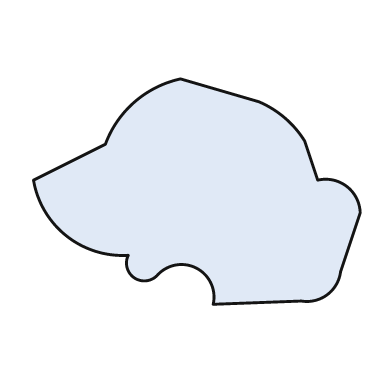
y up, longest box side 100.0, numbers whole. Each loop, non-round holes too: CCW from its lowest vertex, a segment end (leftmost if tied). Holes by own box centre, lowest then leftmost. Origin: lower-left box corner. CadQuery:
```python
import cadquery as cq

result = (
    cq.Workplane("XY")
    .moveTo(55.0, 0.0)
    .lineTo(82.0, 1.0)
    .threePointArc((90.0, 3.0), (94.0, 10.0))
    .lineTo(100.0, 28.0)
    .threePointArc((96.0, 36.0), (87.0, 38.0))
    .lineTo(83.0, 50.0)
    .threePointArc((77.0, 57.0), (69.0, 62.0))
    .lineTo(45.0, 69.0)
    .threePointArc((31.0, 62.0), (22.0, 49.0))
    .lineTo(0.0, 38.0)
    .threePointArc((10.0, 21.0), (29.0, 15.0))
    .threePointArc((31.0, 8.0), (38.0, 9.0))
    .threePointArc((50.0, 11.0), (55.0, 0.0))
    .close()
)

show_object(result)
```